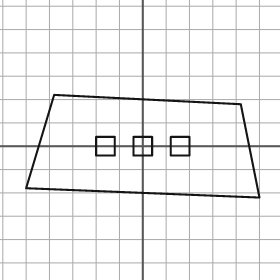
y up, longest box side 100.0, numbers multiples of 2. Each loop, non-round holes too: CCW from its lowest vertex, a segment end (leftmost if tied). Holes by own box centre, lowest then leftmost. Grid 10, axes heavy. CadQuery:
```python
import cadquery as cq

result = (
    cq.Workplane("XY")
    .moveTo(50.0, -22.0)
    .lineTo(42.0, 18.0)
    .lineTo(-38.0, 22.0)
    .lineTo(-50.0, -18.0)
    .close()
    .moveTo(-20.0, -4.0)
    .lineTo(-12.0, -4.0)
    .lineTo(-12.0, 4.0)
    .lineTo(-20.0, 4.0)
    .close()
    .moveTo(-4.0, -4.0)
    .lineTo(4.0, -4.0)
    .lineTo(4.0, 4.0)
    .lineTo(-4.0, 4.0)
    .close()
    .moveTo(12.0, -4.0)
    .lineTo(20.0, -4.0)
    .lineTo(20.0, 4.0)
    .lineTo(12.0, 4.0)
    .close()
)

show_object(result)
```